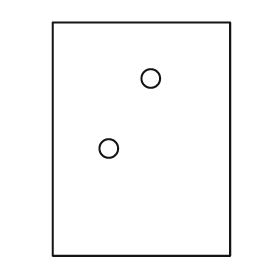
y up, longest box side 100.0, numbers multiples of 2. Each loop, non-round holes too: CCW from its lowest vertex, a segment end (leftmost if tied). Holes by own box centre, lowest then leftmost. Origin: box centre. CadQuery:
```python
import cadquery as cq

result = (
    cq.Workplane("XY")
    .moveTo(-38.0, -50.0)
    .lineTo(38.0, -50.0)
    .lineTo(38.0, 50.0)
    .lineTo(-38.0, 50.0)
    .close()
    .moveTo(-14.0, -4.0)
    .circle(4.0)
    .moveTo(4.0, 26.0)
    .circle(4.0)
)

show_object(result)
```